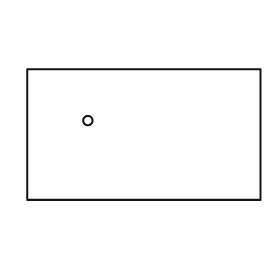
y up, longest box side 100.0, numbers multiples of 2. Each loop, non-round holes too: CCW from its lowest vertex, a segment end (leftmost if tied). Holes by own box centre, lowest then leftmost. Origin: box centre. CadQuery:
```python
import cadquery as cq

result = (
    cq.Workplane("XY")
    .moveTo(-50.0, -28.0)
    .lineTo(50.0, -28.0)
    .lineTo(50.0, 28.0)
    .lineTo(-50.0, 28.0)
    .close()
    .moveTo(-24.0, 6.0)
    .circle(2.0)
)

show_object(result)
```